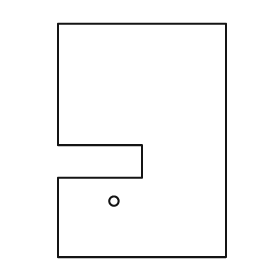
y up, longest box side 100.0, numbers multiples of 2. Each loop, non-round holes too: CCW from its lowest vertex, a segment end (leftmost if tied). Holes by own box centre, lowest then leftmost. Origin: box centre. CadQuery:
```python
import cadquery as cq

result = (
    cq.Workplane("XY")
    .moveTo(-36.0, -50.0)
    .lineTo(36.0, -50.0)
    .lineTo(36.0, 50.0)
    .lineTo(-36.0, 50.0)
    .lineTo(-36.0, -2.0)
    .lineTo(0.0, -2.0)
    .lineTo(0.0, -16.0)
    .lineTo(-36.0, -16.0)
    .close()
    .moveTo(-12.0, -26.0)
    .circle(2.0)
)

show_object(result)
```